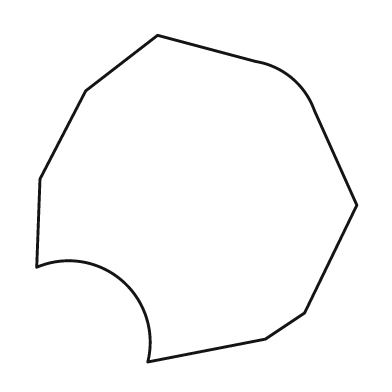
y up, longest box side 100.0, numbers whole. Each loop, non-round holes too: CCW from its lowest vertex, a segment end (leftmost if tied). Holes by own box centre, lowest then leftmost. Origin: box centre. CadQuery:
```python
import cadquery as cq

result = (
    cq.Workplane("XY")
    .moveTo(-15.0, -50.0)
    .lineTo(21.0, -43.0)
    .lineTo(33.0, -35.0)
    .lineTo(49.0, -2.0)
    .lineTo(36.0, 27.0)
    .threePointArc((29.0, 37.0), (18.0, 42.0))
    .lineTo(-12.0, 50.0)
    .lineTo(-34.0, 33.0)
    .lineTo(-48.0, 6.0)
    .lineTo(-49.0, -21.0)
    .threePointArc((-23.0, -25.0), (-15.0, -50.0))
    .close()
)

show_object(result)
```